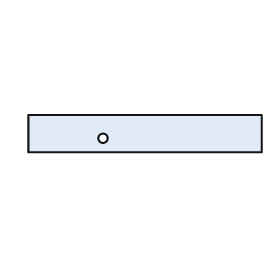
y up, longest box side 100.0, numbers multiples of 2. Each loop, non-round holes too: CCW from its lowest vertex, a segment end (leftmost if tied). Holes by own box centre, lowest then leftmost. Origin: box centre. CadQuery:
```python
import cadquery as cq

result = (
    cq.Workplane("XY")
    .moveTo(-50.0, -8.0)
    .lineTo(50.0, -8.0)
    .lineTo(50.0, 8.0)
    .lineTo(-50.0, 8.0)
    .close()
    .moveTo(-18.0, -2.0)
    .circle(2.0)
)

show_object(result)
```